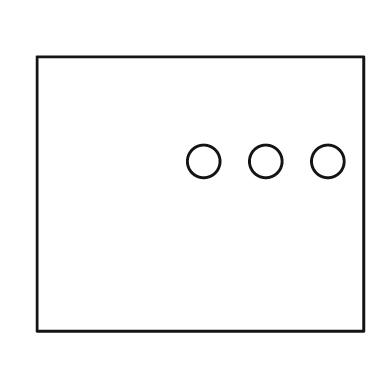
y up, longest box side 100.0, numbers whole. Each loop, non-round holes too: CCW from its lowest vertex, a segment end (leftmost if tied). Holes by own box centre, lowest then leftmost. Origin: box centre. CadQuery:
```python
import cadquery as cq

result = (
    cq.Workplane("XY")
    .moveTo(-50.0, -42.0)
    .lineTo(50.0, -42.0)
    .lineTo(50.0, 42.0)
    .lineTo(-50.0, 42.0)
    .close()
    .moveTo(1.0, 10.0)
    .circle(5.0)
    .moveTo(20.0, 10.0)
    .circle(5.0)
    .moveTo(39.0, 10.0)
    .circle(5.0)
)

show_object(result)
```